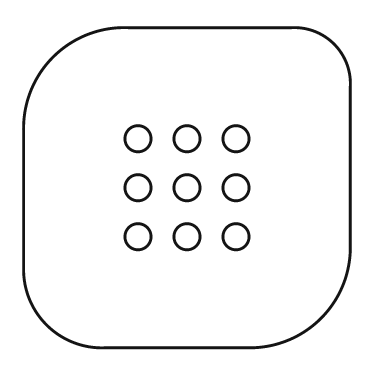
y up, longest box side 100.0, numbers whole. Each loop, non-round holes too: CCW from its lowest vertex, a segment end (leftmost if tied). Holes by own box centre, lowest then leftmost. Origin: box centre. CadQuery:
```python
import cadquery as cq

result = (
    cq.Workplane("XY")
    .moveTo(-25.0, -49.0)
    .lineTo(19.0, -49.0)
    .threePointArc((41.0, -40.0), (50.0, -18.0))
    .lineTo(50.0, 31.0)
    .threePointArc((45.0, 44.0), (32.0, 49.0))
    .lineTo(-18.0, 49.0)
    .threePointArc((-41.0, 40.0), (-50.0, 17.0))
    .lineTo(-50.0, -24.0)
    .threePointArc((-43.0, -42.0), (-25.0, -49.0))
    .close()
    .moveTo(-15.0, -15.0)
    .circle(4.0)
    .moveTo(0.0, -15.0)
    .circle(4.0)
    .moveTo(15.0, -15.0)
    .circle(4.0)
    .moveTo(-15.0, 0.0)
    .circle(4.0)
    .moveTo(0.0, 0.0)
    .circle(4.0)
    .moveTo(15.0, 0.0)
    .circle(4.0)
    .moveTo(-15.0, 15.0)
    .circle(4.0)
    .moveTo(0.0, 15.0)
    .circle(4.0)
    .moveTo(15.0, 15.0)
    .circle(4.0)
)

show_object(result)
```